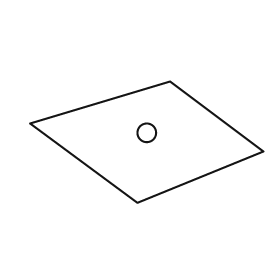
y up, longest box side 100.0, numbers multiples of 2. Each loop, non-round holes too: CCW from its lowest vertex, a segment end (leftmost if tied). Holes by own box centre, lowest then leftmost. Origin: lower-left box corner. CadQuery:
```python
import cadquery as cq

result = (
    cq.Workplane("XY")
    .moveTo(46.0, 0.0)
    .lineTo(100.0, 22.0)
    .lineTo(60.0, 52.0)
    .lineTo(0.0, 34.0)
    .close()
    .moveTo(50.0, 30.0)
    .circle(4.0)
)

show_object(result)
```